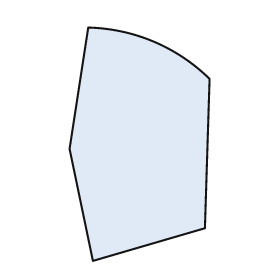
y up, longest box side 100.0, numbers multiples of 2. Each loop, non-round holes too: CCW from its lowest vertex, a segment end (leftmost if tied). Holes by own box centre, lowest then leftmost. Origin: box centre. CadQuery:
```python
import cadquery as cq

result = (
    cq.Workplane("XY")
    .moveTo(-20.0, -50.0)
    .lineTo(28.0, -36.0)
    .lineTo(30.0, 28.0)
    .threePointArc((6.0, 44.0), (-22.0, 50.0))
    .lineTo(-30.0, -2.0)
    .close()
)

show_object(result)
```